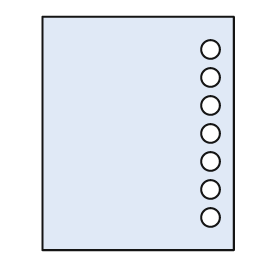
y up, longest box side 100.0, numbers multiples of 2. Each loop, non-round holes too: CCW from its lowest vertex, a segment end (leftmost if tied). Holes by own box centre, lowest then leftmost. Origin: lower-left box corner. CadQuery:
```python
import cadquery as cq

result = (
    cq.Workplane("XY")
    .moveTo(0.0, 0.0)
    .lineTo(82.0, 0.0)
    .lineTo(82.0, 100.0)
    .lineTo(0.0, 100.0)
    .close()
    .moveTo(72.0, 14.0)
    .circle(4.0)
    .moveTo(72.0, 26.0)
    .circle(4.0)
    .moveTo(72.0, 38.0)
    .circle(4.0)
    .moveTo(72.0, 50.0)
    .circle(4.0)
    .moveTo(72.0, 62.0)
    .circle(4.0)
    .moveTo(72.0, 74.0)
    .circle(4.0)
    .moveTo(72.0, 86.0)
    .circle(4.0)
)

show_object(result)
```